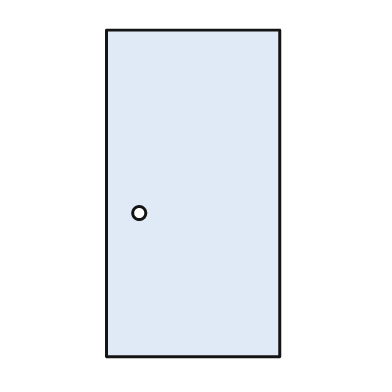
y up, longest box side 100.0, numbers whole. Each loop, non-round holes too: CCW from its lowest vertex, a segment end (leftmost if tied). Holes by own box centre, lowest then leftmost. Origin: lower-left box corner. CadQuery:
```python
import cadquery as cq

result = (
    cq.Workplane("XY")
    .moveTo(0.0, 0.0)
    .lineTo(53.0, 0.0)
    .lineTo(53.0, 100.0)
    .lineTo(0.0, 100.0)
    .close()
    .moveTo(10.0, 44.0)
    .circle(2.0)
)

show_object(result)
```